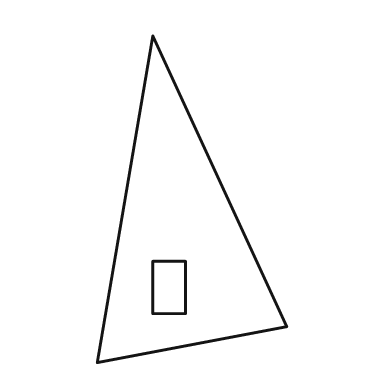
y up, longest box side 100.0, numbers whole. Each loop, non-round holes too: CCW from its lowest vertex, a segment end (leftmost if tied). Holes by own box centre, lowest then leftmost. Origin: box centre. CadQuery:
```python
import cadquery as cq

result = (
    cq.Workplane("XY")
    .moveTo(-29.0, -50.0)
    .lineTo(29.0, -39.0)
    .lineTo(-12.0, 50.0)
    .close()
    .moveTo(-12.0, -35.0)
    .lineTo(-2.0, -35.0)
    .lineTo(-2.0, -19.0)
    .lineTo(-12.0, -19.0)
    .close()
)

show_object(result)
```